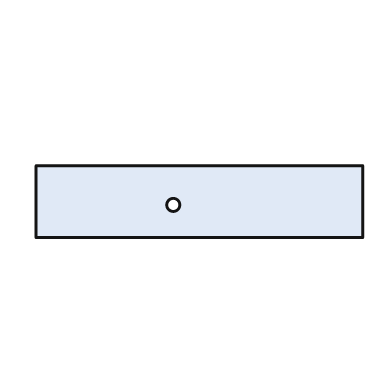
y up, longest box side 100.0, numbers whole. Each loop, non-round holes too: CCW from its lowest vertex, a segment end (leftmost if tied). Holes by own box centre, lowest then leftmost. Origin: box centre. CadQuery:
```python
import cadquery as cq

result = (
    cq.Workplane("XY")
    .moveTo(-50.0, -11.0)
    .lineTo(50.0, -11.0)
    .lineTo(50.0, 11.0)
    .lineTo(-50.0, 11.0)
    .close()
    .moveTo(-8.0, -1.0)
    .circle(2.0)
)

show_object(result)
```